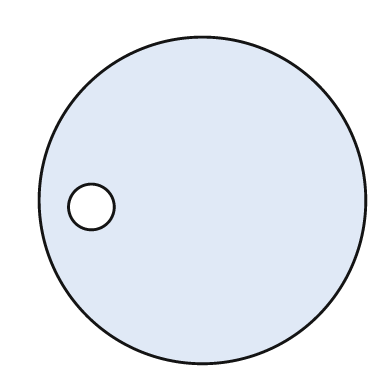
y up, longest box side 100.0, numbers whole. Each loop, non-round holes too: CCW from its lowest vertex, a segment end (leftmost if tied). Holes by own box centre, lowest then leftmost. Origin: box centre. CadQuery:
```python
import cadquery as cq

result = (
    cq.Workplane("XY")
    .moveTo(0.0, 0.0)
    .circle(50.0)
    .moveTo(-34.0, -2.0)
    .circle(7.0)
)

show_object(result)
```